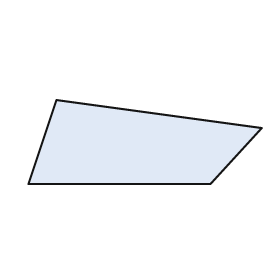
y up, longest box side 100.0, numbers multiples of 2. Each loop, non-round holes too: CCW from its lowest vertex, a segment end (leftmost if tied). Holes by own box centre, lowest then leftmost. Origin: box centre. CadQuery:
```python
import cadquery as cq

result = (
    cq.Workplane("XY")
    .moveTo(-50.0, -18.0)
    .lineTo(28.0, -18.0)
    .lineTo(50.0, 6.0)
    .lineTo(-38.0, 18.0)
    .close()
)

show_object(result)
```